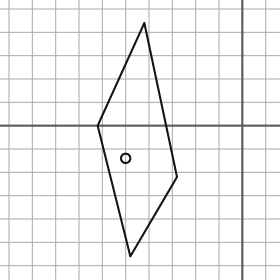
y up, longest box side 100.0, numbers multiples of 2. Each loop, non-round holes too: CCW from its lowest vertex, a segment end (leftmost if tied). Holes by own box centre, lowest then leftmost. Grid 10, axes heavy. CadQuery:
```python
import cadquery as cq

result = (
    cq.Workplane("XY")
    .moveTo(-48.0, -56.0)
    .lineTo(-28.0, -22.0)
    .lineTo(-42.0, 44.0)
    .lineTo(-62.0, 0.0)
    .close()
    .moveTo(-50.0, -14.0)
    .circle(2.0)
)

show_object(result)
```